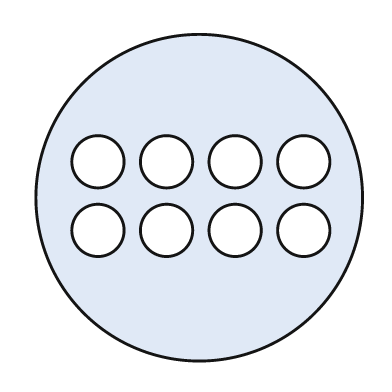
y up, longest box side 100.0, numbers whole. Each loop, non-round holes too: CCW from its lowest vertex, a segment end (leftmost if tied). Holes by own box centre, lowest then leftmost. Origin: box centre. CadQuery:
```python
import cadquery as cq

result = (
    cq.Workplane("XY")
    .moveTo(0.0, 0.0)
    .circle(50.0)
    .moveTo(-31.0, -10.0)
    .circle(8.0)
    .moveTo(-10.0, -10.0)
    .circle(8.0)
    .moveTo(11.0, -10.0)
    .circle(8.0)
    .moveTo(32.0, -10.0)
    .circle(8.0)
    .moveTo(-31.0, 11.0)
    .circle(8.0)
    .moveTo(-10.0, 11.0)
    .circle(8.0)
    .moveTo(11.0, 11.0)
    .circle(8.0)
    .moveTo(32.0, 11.0)
    .circle(8.0)
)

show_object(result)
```